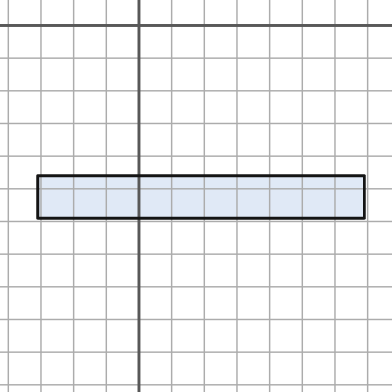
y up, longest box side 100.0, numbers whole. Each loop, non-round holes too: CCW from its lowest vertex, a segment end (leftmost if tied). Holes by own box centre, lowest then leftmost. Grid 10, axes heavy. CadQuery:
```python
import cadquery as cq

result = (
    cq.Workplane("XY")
    .moveTo(-31.0, -59.0)
    .lineTo(69.0, -59.0)
    .lineTo(69.0, -46.0)
    .lineTo(-31.0, -46.0)
    .close()
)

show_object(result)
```